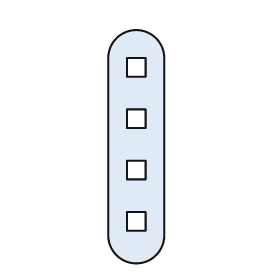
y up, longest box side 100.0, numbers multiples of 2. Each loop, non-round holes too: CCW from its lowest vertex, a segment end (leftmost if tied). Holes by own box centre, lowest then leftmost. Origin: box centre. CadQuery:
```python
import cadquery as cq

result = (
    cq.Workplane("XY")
    .moveTo(-12.0, -38.0)
    .threePointArc((0.0, -50.0), (12.0, -38.0))
    .lineTo(12.0, 38.0)
    .threePointArc((0.0, 50.0), (-12.0, 38.0))
    .close()
    .moveTo(-4.0, -36.0)
    .lineTo(4.0, -36.0)
    .lineTo(4.0, -28.0)
    .lineTo(-4.0, -28.0)
    .close()
    .moveTo(-4.0, -14.0)
    .lineTo(4.0, -14.0)
    .lineTo(4.0, -6.0)
    .lineTo(-4.0, -6.0)
    .close()
    .moveTo(-4.0, 8.0)
    .lineTo(4.0, 8.0)
    .lineTo(4.0, 16.0)
    .lineTo(-4.0, 16.0)
    .close()
    .moveTo(-4.0, 30.0)
    .lineTo(4.0, 30.0)
    .lineTo(4.0, 38.0)
    .lineTo(-4.0, 38.0)
    .close()
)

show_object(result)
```